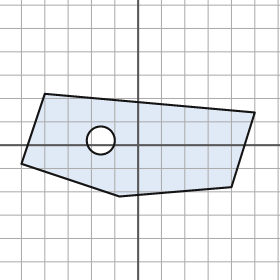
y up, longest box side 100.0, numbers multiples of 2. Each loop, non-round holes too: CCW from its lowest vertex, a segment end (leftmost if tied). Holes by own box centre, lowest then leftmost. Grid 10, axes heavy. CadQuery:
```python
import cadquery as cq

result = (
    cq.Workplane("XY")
    .moveTo(-8.0, -22.0)
    .lineTo(40.0, -18.0)
    .lineTo(50.0, 14.0)
    .lineTo(-40.0, 22.0)
    .lineTo(-50.0, -8.0)
    .close()
    .moveTo(-16.0, 2.0)
    .circle(6.0)
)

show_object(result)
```